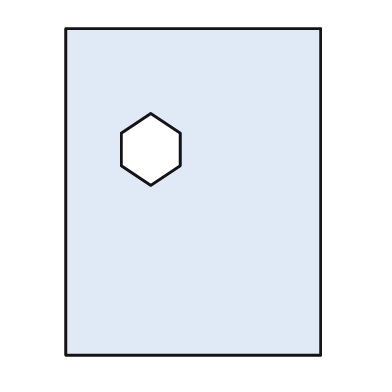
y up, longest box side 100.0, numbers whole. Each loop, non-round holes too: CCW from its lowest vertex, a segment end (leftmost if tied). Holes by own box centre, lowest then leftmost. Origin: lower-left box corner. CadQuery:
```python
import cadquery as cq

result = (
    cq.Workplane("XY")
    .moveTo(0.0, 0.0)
    .lineTo(78.0, 0.0)
    .lineTo(78.0, 100.0)
    .lineTo(0.0, 100.0)
    .close()
    .moveTo(26.0, 52.0)
    .lineTo(35.0, 58.0)
    .lineTo(35.0, 68.0)
    .lineTo(26.0, 74.0)
    .lineTo(17.0, 68.0)
    .lineTo(17.0, 58.0)
    .close()
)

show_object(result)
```